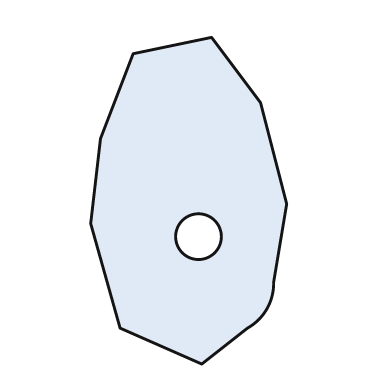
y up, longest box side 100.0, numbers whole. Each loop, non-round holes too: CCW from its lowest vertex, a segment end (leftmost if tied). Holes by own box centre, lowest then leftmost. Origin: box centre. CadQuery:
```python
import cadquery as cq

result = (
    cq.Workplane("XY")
    .moveTo(4.0, -50.0)
    .lineTo(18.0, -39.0)
    .threePointArc((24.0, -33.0), (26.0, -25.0))
    .lineTo(30.0, -1.0)
    .lineTo(22.0, 30.0)
    .lineTo(7.0, 50.0)
    .lineTo(-17.0, 45.0)
    .lineTo(-27.0, 19.0)
    .lineTo(-30.0, -7.0)
    .lineTo(-21.0, -39.0)
    .close()
    .moveTo(3.0, -11.0)
    .circle(7.0)
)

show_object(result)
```